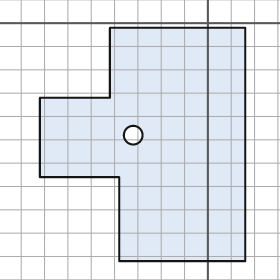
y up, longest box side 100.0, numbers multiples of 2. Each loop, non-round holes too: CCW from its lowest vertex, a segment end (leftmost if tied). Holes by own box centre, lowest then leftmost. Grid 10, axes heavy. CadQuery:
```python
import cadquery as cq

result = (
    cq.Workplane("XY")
    .moveTo(-38.0, -102.0)
    .lineTo(16.0, -102.0)
    .lineTo(16.0, -2.0)
    .lineTo(-42.0, -2.0)
    .lineTo(-42.0, -32.0)
    .lineTo(-72.0, -32.0)
    .lineTo(-72.0, -66.0)
    .lineTo(-38.0, -66.0)
    .close()
    .moveTo(-32.0, -48.0)
    .circle(4.0)
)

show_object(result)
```